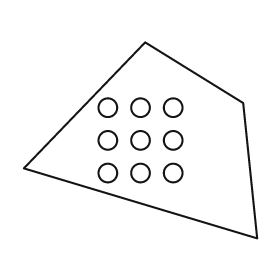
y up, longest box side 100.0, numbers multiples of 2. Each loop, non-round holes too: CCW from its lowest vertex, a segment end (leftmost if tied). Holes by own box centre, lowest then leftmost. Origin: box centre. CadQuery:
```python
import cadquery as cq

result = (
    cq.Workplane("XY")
    .moveTo(50.0, -42.0)
    .lineTo(44.0, 16.0)
    .lineTo(2.0, 42.0)
    .lineTo(-50.0, -12.0)
    .close()
    .moveTo(-14.0, -14.0)
    .circle(4.0)
    .moveTo(0.0, -14.0)
    .circle(4.0)
    .moveTo(14.0, -14.0)
    .circle(4.0)
    .moveTo(-14.0, 0.0)
    .circle(4.0)
    .moveTo(0.0, 0.0)
    .circle(4.0)
    .moveTo(14.0, 0.0)
    .circle(4.0)
    .moveTo(-14.0, 14.0)
    .circle(4.0)
    .moveTo(0.0, 14.0)
    .circle(4.0)
    .moveTo(14.0, 14.0)
    .circle(4.0)
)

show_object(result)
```